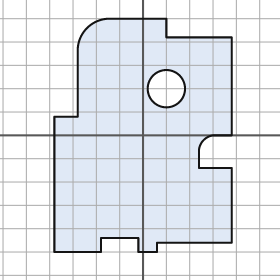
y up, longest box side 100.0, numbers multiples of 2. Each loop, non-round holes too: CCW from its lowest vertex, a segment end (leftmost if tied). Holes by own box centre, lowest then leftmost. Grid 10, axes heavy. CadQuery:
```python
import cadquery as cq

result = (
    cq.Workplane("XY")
    .moveTo(-38.0, -50.0)
    .lineTo(-18.0, -50.0)
    .lineTo(-18.0, -44.0)
    .lineTo(-2.0, -44.0)
    .lineTo(-2.0, -50.0)
    .lineTo(6.0, -50.0)
    .lineTo(6.0, -46.0)
    .lineTo(38.0, -46.0)
    .lineTo(38.0, -14.0)
    .lineTo(24.0, -14.0)
    .lineTo(24.0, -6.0)
    .threePointArc((26.0, -2.0), (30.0, 0.0))
    .lineTo(38.0, 0.0)
    .lineTo(38.0, 42.0)
    .lineTo(10.0, 42.0)
    .lineTo(10.0, 50.0)
    .lineTo(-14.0, 50.0)
    .threePointArc((-24.0, 46.0), (-28.0, 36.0))
    .lineTo(-28.0, 8.0)
    .lineTo(-38.0, 8.0)
    .close()
    .moveTo(10.0, 20.0)
    .circle(8.0)
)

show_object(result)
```